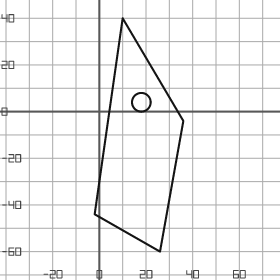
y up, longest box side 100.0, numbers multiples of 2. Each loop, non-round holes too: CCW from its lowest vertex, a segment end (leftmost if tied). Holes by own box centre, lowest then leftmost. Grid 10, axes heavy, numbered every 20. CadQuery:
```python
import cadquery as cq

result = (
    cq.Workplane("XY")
    .moveTo(26.0, -60.0)
    .lineTo(36.0, -4.0)
    .lineTo(10.0, 40.0)
    .lineTo(-2.0, -44.0)
    .close()
    .moveTo(18.0, 4.0)
    .circle(4.0)
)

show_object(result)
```